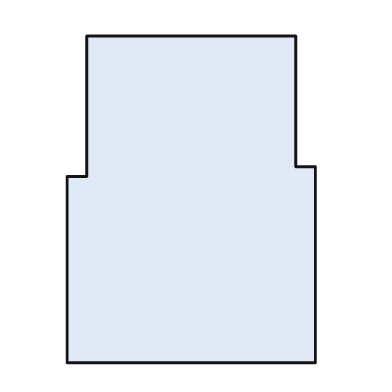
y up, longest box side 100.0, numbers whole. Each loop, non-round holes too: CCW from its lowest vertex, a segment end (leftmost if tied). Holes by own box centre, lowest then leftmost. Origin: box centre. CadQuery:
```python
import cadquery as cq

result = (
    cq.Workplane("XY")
    .moveTo(-38.0, -50.0)
    .lineTo(38.0, -50.0)
    .lineTo(38.0, 10.0)
    .lineTo(32.0, 10.0)
    .lineTo(32.0, 50.0)
    .lineTo(-32.0, 50.0)
    .lineTo(-32.0, 7.0)
    .lineTo(-38.0, 7.0)
    .close()
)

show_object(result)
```